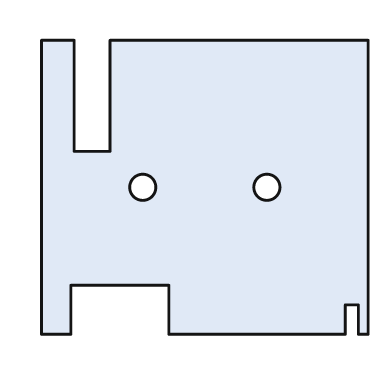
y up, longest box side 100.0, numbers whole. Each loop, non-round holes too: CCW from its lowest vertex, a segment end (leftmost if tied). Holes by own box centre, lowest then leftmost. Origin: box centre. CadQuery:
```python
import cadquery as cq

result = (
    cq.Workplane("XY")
    .moveTo(-50.0, -45.0)
    .lineTo(-41.0, -45.0)
    .lineTo(-41.0, -30.0)
    .lineTo(-11.0, -30.0)
    .lineTo(-11.0, -45.0)
    .lineTo(43.0, -45.0)
    .lineTo(43.0, -36.0)
    .lineTo(47.0, -36.0)
    .lineTo(47.0, -45.0)
    .lineTo(50.0, -45.0)
    .lineTo(50.0, 45.0)
    .lineTo(-29.0, 45.0)
    .lineTo(-29.0, 11.0)
    .lineTo(-40.0, 11.0)
    .lineTo(-40.0, 45.0)
    .lineTo(-50.0, 45.0)
    .close()
    .moveTo(-19.0, 0.0)
    .circle(4.0)
    .moveTo(19.0, 0.0)
    .circle(4.0)
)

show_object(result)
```